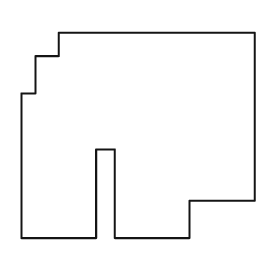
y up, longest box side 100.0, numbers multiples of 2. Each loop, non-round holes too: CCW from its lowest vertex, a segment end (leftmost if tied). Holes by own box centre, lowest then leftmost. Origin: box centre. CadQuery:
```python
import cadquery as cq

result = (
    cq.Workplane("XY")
    .moveTo(-50.0, -44.0)
    .lineTo(-18.0, -44.0)
    .lineTo(-18.0, -6.0)
    .lineTo(-10.0, -6.0)
    .lineTo(-10.0, -44.0)
    .lineTo(22.0, -44.0)
    .lineTo(22.0, -28.0)
    .lineTo(50.0, -28.0)
    .lineTo(50.0, 44.0)
    .lineTo(-34.0, 44.0)
    .lineTo(-34.0, 34.0)
    .lineTo(-44.0, 34.0)
    .lineTo(-44.0, 18.0)
    .lineTo(-50.0, 18.0)
    .close()
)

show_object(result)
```